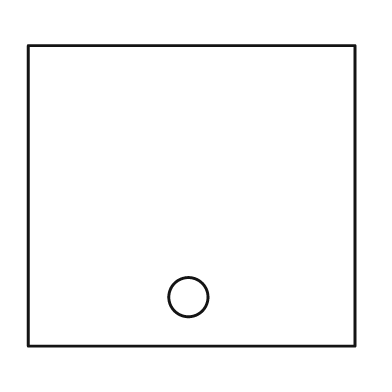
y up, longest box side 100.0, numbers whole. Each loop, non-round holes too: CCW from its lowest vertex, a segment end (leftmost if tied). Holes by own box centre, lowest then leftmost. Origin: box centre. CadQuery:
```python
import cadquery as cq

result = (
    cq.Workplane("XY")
    .moveTo(-50.0, -46.0)
    .lineTo(50.0, -46.0)
    .lineTo(50.0, 46.0)
    .lineTo(-50.0, 46.0)
    .close()
    .moveTo(-1.0, -31.0)
    .circle(6.0)
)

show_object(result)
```